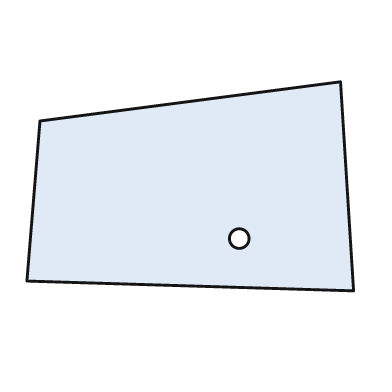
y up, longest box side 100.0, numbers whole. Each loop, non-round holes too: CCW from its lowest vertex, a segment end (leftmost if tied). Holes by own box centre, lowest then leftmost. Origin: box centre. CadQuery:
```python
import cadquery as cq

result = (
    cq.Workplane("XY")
    .moveTo(50.0, -32.0)
    .lineTo(46.0, 32.0)
    .lineTo(-46.0, 20.0)
    .lineTo(-50.0, -29.0)
    .close()
    .moveTo(15.0, -16.0)
    .circle(3.0)
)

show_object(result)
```